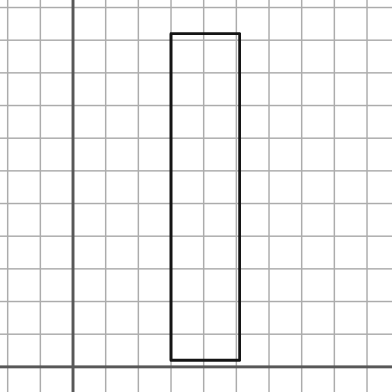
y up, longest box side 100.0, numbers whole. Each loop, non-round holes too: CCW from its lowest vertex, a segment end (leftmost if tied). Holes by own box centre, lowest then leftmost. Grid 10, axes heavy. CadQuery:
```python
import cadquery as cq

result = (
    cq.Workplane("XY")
    .moveTo(30.0, 2.0)
    .lineTo(51.0, 2.0)
    .lineTo(51.0, 102.0)
    .lineTo(30.0, 102.0)
    .close()
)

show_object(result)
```